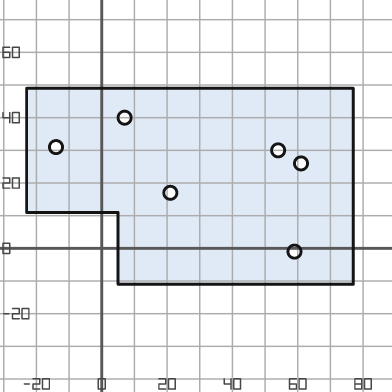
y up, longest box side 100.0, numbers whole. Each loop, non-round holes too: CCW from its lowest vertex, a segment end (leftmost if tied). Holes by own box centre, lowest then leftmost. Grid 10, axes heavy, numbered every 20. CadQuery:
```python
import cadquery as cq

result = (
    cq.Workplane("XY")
    .moveTo(5.0, -11.0)
    .lineTo(77.0, -11.0)
    .lineTo(77.0, 49.0)
    .lineTo(-23.0, 49.0)
    .lineTo(-23.0, 11.0)
    .lineTo(5.0, 11.0)
    .close()
    .moveTo(59.0, -1.0)
    .circle(2.0)
    .moveTo(21.0, 17.0)
    .circle(2.0)
    .moveTo(61.0, 26.0)
    .circle(2.0)
    .moveTo(54.0, 30.0)
    .circle(2.0)
    .moveTo(-14.0, 31.0)
    .circle(2.0)
    .moveTo(7.0, 40.0)
    .circle(2.0)
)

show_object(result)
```